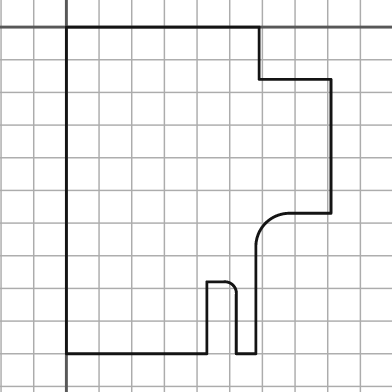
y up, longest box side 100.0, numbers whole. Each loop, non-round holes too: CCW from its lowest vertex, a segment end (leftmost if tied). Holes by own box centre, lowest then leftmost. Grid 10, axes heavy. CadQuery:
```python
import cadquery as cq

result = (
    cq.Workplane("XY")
    .moveTo(0.0, -100.0)
    .lineTo(43.0, -100.0)
    .lineTo(43.0, -78.0)
    .lineTo(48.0, -78.0)
    .threePointArc((51.0, -79.0), (52.0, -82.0))
    .lineTo(52.0, -100.0)
    .lineTo(58.0, -100.0)
    .lineTo(58.0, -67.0)
    .threePointArc((61.0, -60.0), (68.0, -57.0))
    .lineTo(81.0, -57.0)
    .lineTo(81.0, -16.0)
    .lineTo(59.0, -16.0)
    .lineTo(59.0, 0.0)
    .lineTo(0.0, 0.0)
    .close()
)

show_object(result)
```